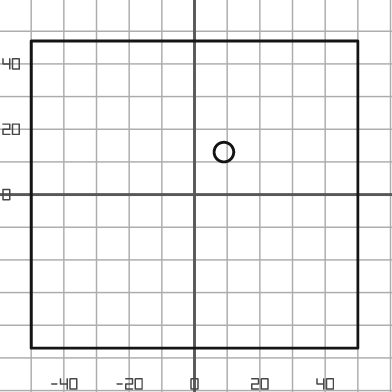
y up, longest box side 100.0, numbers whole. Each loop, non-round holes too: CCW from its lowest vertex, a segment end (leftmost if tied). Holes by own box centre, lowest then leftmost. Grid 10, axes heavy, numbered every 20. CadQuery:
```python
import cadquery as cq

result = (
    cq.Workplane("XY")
    .moveTo(-50.0, -47.0)
    .lineTo(50.0, -47.0)
    .lineTo(50.0, 47.0)
    .lineTo(-50.0, 47.0)
    .close()
    .moveTo(9.0, 13.0)
    .circle(3.0)
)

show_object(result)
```